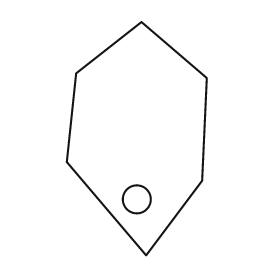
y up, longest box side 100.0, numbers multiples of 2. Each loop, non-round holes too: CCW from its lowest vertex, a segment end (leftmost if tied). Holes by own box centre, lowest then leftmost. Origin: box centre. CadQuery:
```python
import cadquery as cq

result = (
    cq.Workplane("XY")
    .moveTo(4.0, -50.0)
    .lineTo(28.0, -18.0)
    .lineTo(30.0, 26.0)
    .lineTo(2.0, 50.0)
    .lineTo(-26.0, 28.0)
    .lineTo(-30.0, -10.0)
    .close()
    .moveTo(0.0, -26.0)
    .circle(6.0)
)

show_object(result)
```